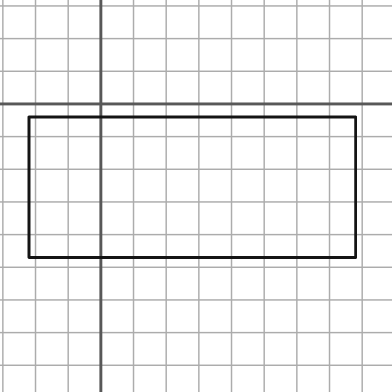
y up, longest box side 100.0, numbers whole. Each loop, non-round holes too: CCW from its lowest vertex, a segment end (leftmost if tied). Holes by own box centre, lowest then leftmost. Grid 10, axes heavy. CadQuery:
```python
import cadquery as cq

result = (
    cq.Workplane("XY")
    .moveTo(-22.0, -47.0)
    .lineTo(78.0, -47.0)
    .lineTo(78.0, -4.0)
    .lineTo(-22.0, -4.0)
    .close()
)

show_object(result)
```